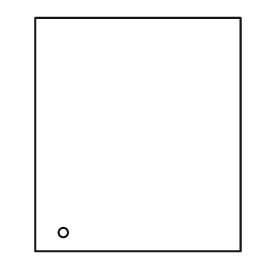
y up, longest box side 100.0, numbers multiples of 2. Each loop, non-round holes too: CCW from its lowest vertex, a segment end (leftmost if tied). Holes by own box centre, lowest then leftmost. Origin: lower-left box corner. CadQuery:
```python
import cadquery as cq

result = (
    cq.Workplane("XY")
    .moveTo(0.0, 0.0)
    .lineTo(88.0, 0.0)
    .lineTo(88.0, 100.0)
    .lineTo(0.0, 100.0)
    .close()
    .moveTo(12.0, 8.0)
    .circle(2.0)
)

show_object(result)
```